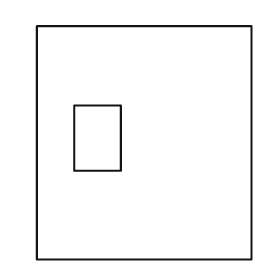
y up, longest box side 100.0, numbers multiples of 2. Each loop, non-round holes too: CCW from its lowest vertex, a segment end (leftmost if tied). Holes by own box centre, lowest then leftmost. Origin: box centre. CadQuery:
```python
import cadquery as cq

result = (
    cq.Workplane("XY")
    .moveTo(-46.0, -50.0)
    .lineTo(46.0, -50.0)
    .lineTo(46.0, 50.0)
    .lineTo(-46.0, 50.0)
    .close()
    .moveTo(-30.0, -12.0)
    .lineTo(-10.0, -12.0)
    .lineTo(-10.0, 16.0)
    .lineTo(-30.0, 16.0)
    .close()
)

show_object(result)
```